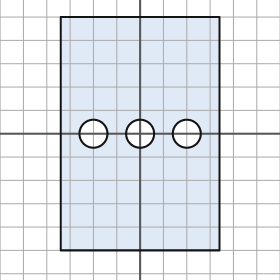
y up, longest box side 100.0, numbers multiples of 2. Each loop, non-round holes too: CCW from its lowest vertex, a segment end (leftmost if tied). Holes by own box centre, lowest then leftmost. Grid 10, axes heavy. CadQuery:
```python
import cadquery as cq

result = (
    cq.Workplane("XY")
    .moveTo(-34.0, -50.0)
    .lineTo(34.0, -50.0)
    .lineTo(34.0, 50.0)
    .lineTo(-34.0, 50.0)
    .close()
    .moveTo(-20.0, 0.0)
    .circle(6.0)
    .moveTo(0.0, 0.0)
    .circle(6.0)
    .moveTo(20.0, 0.0)
    .circle(6.0)
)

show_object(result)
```